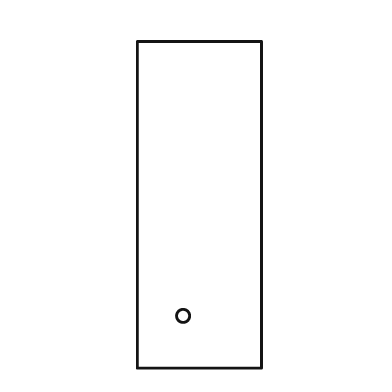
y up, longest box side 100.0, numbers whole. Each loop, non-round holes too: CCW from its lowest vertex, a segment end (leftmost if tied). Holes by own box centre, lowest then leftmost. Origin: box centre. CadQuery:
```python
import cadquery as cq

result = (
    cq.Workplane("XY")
    .moveTo(-19.0, -50.0)
    .lineTo(19.0, -50.0)
    .lineTo(19.0, 50.0)
    .lineTo(-19.0, 50.0)
    .close()
    .moveTo(-5.0, -34.0)
    .circle(2.0)
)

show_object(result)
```